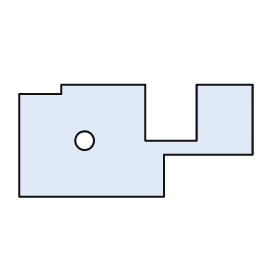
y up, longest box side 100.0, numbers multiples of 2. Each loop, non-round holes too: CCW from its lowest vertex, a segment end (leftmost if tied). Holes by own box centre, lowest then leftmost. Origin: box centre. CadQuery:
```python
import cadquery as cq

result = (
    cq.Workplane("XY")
    .moveTo(-50.0, -24.0)
    .lineTo(12.0, -24.0)
    .lineTo(12.0, -6.0)
    .lineTo(50.0, -6.0)
    .lineTo(50.0, 24.0)
    .lineTo(26.0, 24.0)
    .lineTo(26.0, 0.0)
    .lineTo(4.0, 0.0)
    .lineTo(4.0, 24.0)
    .lineTo(-32.0, 24.0)
    .lineTo(-32.0, 20.0)
    .lineTo(-50.0, 20.0)
    .close()
    .moveTo(-22.0, 0.0)
    .circle(4.0)
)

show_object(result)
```